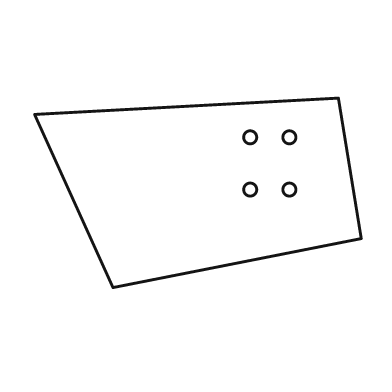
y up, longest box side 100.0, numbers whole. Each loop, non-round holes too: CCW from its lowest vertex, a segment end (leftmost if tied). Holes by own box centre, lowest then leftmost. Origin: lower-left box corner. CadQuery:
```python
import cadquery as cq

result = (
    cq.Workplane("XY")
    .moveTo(24.0, 0.0)
    .lineTo(100.0, 15.0)
    .lineTo(93.0, 58.0)
    .lineTo(0.0, 53.0)
    .close()
    .moveTo(66.0, 30.0)
    .circle(2.0)
    .moveTo(78.0, 30.0)
    .circle(2.0)
    .moveTo(66.0, 46.0)
    .circle(2.0)
    .moveTo(78.0, 46.0)
    .circle(2.0)
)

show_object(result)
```